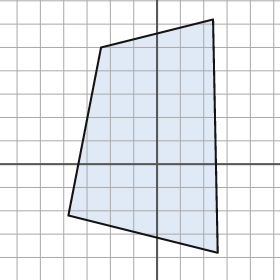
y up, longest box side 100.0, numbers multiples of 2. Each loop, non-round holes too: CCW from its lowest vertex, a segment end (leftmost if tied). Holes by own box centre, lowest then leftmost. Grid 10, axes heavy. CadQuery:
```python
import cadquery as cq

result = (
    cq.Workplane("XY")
    .moveTo(26.0, -38.0)
    .lineTo(24.0, 62.0)
    .lineTo(-24.0, 50.0)
    .lineTo(-38.0, -22.0)
    .close()
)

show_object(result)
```